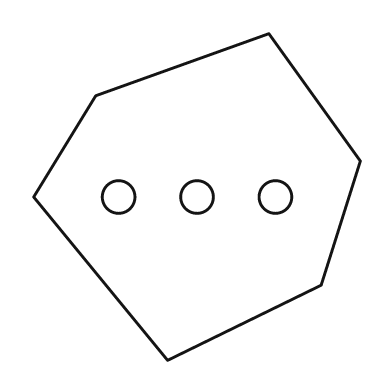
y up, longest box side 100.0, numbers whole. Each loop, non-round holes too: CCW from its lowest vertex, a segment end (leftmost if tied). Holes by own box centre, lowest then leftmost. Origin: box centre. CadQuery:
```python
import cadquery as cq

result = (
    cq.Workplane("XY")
    .moveTo(-9.0, -50.0)
    .lineTo(38.0, -27.0)
    .lineTo(50.0, 11.0)
    .lineTo(22.0, 50.0)
    .lineTo(-31.0, 31.0)
    .lineTo(-50.0, 0.0)
    .close()
    .moveTo(-24.0, 0.0)
    .circle(5.0)
    .moveTo(0.0, 0.0)
    .circle(5.0)
    .moveTo(24.0, 0.0)
    .circle(5.0)
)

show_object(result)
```